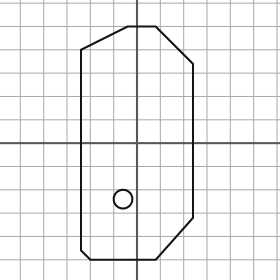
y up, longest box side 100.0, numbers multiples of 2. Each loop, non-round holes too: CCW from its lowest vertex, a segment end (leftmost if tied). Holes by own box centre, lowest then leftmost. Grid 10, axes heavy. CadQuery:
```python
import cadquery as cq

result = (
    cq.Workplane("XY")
    .moveTo(-20.0, -50.0)
    .lineTo(8.0, -50.0)
    .lineTo(24.0, -32.0)
    .lineTo(24.0, 34.0)
    .lineTo(8.0, 50.0)
    .lineTo(-4.0, 50.0)
    .lineTo(-24.0, 40.0)
    .lineTo(-24.0, -46.0)
    .close()
    .moveTo(-6.0, -24.0)
    .circle(4.0)
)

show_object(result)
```